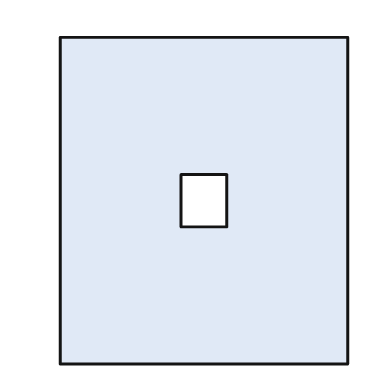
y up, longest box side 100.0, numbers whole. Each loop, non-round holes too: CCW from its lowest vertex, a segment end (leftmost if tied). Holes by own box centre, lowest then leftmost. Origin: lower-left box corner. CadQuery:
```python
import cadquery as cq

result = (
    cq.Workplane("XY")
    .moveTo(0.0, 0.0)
    .lineTo(88.0, 0.0)
    .lineTo(88.0, 100.0)
    .lineTo(0.0, 100.0)
    .close()
    .moveTo(37.0, 42.0)
    .lineTo(51.0, 42.0)
    .lineTo(51.0, 58.0)
    .lineTo(37.0, 58.0)
    .close()
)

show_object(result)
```